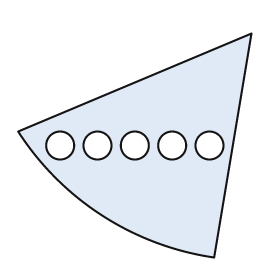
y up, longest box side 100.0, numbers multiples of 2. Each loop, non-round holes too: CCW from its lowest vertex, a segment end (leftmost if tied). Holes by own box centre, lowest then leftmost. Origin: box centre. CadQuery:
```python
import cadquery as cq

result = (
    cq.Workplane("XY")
    .moveTo(34.0, -48.0)
    .lineTo(50.0, 48.0)
    .lineTo(-50.0, 6.0)
    .threePointArc((-14.0, -30.0), (34.0, -48.0))
    .close()
    .moveTo(-32.0, 0.0)
    .circle(6.0)
    .moveTo(-16.0, 0.0)
    .circle(6.0)
    .moveTo(0.0, 0.0)
    .circle(6.0)
    .moveTo(16.0, 0.0)
    .circle(6.0)
    .moveTo(32.0, 0.0)
    .circle(6.0)
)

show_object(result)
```